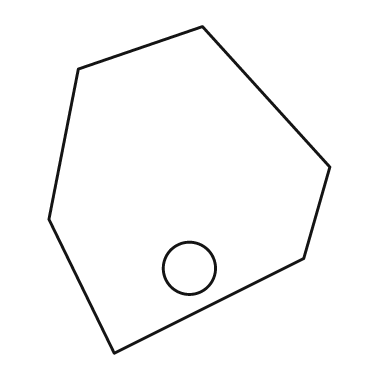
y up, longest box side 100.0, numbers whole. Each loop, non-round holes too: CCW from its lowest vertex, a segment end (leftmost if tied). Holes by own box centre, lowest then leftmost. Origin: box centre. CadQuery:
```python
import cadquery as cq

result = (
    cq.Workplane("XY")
    .moveTo(-23.0, -50.0)
    .lineTo(35.0, -21.0)
    .lineTo(43.0, 7.0)
    .lineTo(4.0, 50.0)
    .lineTo(-34.0, 37.0)
    .lineTo(-43.0, -9.0)
    .close()
    .moveTo(0.0, -24.0)
    .circle(8.0)
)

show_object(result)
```